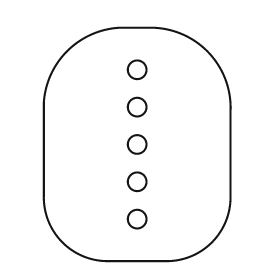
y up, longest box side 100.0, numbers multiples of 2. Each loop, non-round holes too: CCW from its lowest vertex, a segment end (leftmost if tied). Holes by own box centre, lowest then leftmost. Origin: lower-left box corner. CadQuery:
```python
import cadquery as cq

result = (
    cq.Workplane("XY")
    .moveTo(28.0, 0.0)
    .lineTo(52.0, 0.0)
    .threePointArc((72.0, 8.0), (80.0, 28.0))
    .lineTo(80.0, 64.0)
    .threePointArc((70.0, 90.0), (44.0, 100.0))
    .lineTo(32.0, 100.0)
    .threePointArc((10.0, 90.0), (0.0, 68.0))
    .lineTo(0.0, 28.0)
    .threePointArc((8.0, 8.0), (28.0, 0.0))
    .close()
    .moveTo(40.0, 18.0)
    .circle(4.0)
    .moveTo(40.0, 34.0)
    .circle(4.0)
    .moveTo(40.0, 50.0)
    .circle(4.0)
    .moveTo(40.0, 66.0)
    .circle(4.0)
    .moveTo(40.0, 82.0)
    .circle(4.0)
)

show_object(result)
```